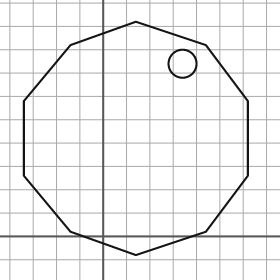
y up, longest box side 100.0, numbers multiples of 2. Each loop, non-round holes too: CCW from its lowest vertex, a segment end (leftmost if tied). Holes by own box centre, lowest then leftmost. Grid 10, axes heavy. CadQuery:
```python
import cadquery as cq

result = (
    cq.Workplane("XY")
    .moveTo(14.0, -8.0)
    .lineTo(44.0, 2.0)
    .lineTo(62.0, 26.0)
    .lineTo(62.0, 58.0)
    .lineTo(44.0, 82.0)
    .lineTo(14.0, 92.0)
    .lineTo(-14.0, 82.0)
    .lineTo(-34.0, 58.0)
    .lineTo(-34.0, 26.0)
    .lineTo(-14.0, 2.0)
    .close()
    .moveTo(34.0, 74.0)
    .circle(6.0)
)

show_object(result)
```